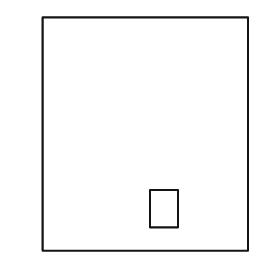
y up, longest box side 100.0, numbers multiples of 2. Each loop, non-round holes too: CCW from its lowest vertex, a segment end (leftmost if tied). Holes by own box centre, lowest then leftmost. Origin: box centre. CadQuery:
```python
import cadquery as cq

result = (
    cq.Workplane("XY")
    .moveTo(-44.0, -50.0)
    .lineTo(44.0, -50.0)
    .lineTo(44.0, 50.0)
    .lineTo(-44.0, 50.0)
    .close()
    .moveTo(2.0, -40.0)
    .lineTo(14.0, -40.0)
    .lineTo(14.0, -24.0)
    .lineTo(2.0, -24.0)
    .close()
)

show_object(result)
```